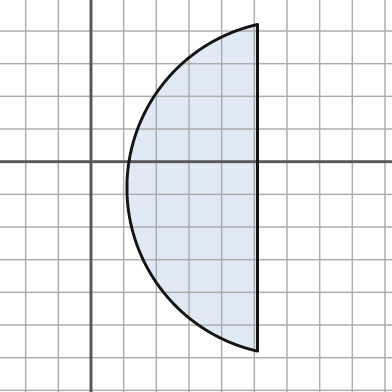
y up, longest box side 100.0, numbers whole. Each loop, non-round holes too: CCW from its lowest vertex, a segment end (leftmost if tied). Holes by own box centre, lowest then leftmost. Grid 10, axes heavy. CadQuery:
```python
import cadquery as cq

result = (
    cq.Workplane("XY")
    .moveTo(51.0, -58.0)
    .lineTo(51.0, 42.0)
    .threePointArc((11.0, -8.0), (51.0, -58.0))
    .close()
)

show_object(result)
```